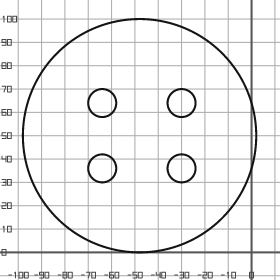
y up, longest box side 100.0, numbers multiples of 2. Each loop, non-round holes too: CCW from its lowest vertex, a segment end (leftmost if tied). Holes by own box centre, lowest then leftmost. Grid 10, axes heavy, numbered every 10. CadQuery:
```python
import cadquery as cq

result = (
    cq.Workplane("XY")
    .moveTo(-48.0, 50.0)
    .circle(50.0)
    .moveTo(-64.0, 36.0)
    .circle(6.0)
    .moveTo(-30.0, 36.0)
    .circle(6.0)
    .moveTo(-64.0, 64.0)
    .circle(6.0)
    .moveTo(-30.0, 64.0)
    .circle(6.0)
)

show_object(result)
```